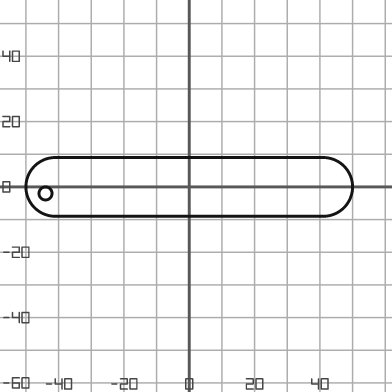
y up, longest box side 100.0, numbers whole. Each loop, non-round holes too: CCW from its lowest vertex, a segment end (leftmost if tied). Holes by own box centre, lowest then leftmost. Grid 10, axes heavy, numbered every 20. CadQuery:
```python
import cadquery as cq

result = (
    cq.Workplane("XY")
    .moveTo(-41.0, -9.0)
    .lineTo(41.0, -9.0)
    .threePointArc((50.0, 0.0), (41.0, 9.0))
    .lineTo(-41.0, 9.0)
    .threePointArc((-50.0, 0.0), (-41.0, -9.0))
    .close()
    .moveTo(-44.0, -2.0)
    .circle(2.0)
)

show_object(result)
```